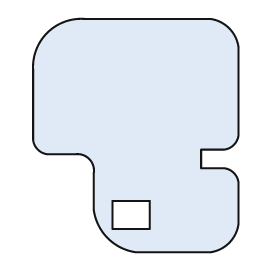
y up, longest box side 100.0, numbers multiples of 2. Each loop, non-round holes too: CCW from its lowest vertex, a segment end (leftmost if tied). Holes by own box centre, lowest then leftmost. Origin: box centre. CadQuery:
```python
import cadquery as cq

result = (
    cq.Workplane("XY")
    .moveTo(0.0, -50.0)
    .lineTo(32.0, -50.0)
    .threePointArc((40.0, -46.0), (44.0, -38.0))
    .lineTo(44.0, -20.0)
    .threePointArc((42.0, -16.0), (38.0, -14.0))
    .lineTo(28.0, -14.0)
    .lineTo(28.0, -6.0)
    .lineTo(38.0, -6.0)
    .threePointArc((42.0, -4.0), (44.0, 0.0))
    .lineTo(44.0, 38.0)
    .threePointArc((40.0, 46.0), (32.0, 50.0))
    .lineTo(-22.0, 50.0)
    .threePointArc((-38.0, 44.0), (-44.0, 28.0))
    .lineTo(-44.0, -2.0)
    .threePointArc((-42.0, -6.0), (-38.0, -8.0))
    .lineTo(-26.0, -8.0)
    .threePointArc((-20.0, -10.0), (-18.0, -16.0))
    .lineTo(-18.0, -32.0)
    .threePointArc((-12.0, -44.0), (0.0, -50.0))
    .close()
    .moveTo(-10.0, -40.0)
    .lineTo(6.0, -40.0)
    .lineTo(6.0, -28.0)
    .lineTo(-10.0, -28.0)
    .close()
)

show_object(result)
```